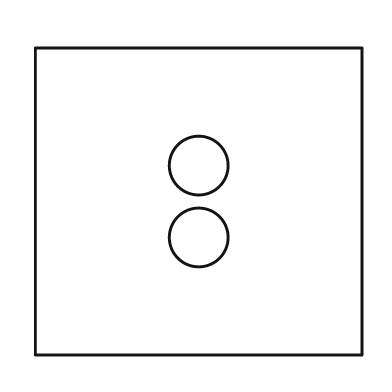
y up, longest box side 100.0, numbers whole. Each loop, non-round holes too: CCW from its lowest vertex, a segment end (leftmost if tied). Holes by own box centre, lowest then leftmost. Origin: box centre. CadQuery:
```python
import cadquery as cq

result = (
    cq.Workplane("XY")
    .moveTo(-50.0, -47.0)
    .lineTo(50.0, -47.0)
    .lineTo(50.0, 47.0)
    .lineTo(-50.0, 47.0)
    .close()
    .moveTo(0.0, -11.0)
    .circle(9.0)
    .moveTo(0.0, 11.0)
    .circle(9.0)
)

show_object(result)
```